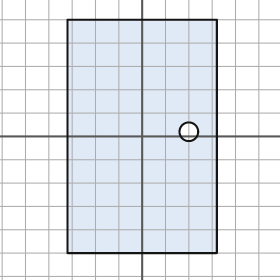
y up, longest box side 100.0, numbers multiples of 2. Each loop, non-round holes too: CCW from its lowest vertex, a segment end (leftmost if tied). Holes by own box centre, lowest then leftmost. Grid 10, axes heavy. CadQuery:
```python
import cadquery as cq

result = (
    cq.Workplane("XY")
    .moveTo(-32.0, -50.0)
    .lineTo(32.0, -50.0)
    .lineTo(32.0, 50.0)
    .lineTo(-32.0, 50.0)
    .close()
    .moveTo(20.0, 2.0)
    .circle(4.0)
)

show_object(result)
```